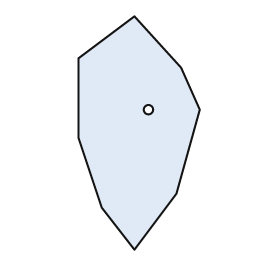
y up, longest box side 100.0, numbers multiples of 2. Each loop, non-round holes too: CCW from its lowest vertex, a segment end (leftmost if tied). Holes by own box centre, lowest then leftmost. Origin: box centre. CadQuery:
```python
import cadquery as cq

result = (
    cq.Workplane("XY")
    .moveTo(-2.0, -50.0)
    .lineTo(16.0, -26.0)
    .lineTo(26.0, 10.0)
    .lineTo(18.0, 28.0)
    .lineTo(-2.0, 50.0)
    .lineTo(-26.0, 32.0)
    .lineTo(-26.0, -2.0)
    .lineTo(-16.0, -32.0)
    .close()
    .moveTo(4.0, 10.0)
    .circle(2.0)
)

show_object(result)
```